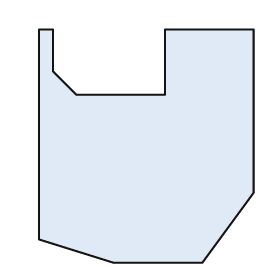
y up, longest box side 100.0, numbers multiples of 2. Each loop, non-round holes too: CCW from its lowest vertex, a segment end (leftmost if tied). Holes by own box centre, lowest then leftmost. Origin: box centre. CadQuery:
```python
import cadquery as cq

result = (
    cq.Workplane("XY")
    .moveTo(-14.0, -50.0)
    .lineTo(24.0, -50.0)
    .lineTo(46.0, -20.0)
    .lineTo(46.0, 50.0)
    .lineTo(8.0, 50.0)
    .lineTo(8.0, 22.0)
    .lineTo(-30.0, 22.0)
    .lineTo(-40.0, 32.0)
    .lineTo(-40.0, 50.0)
    .lineTo(-46.0, 50.0)
    .lineTo(-46.0, -40.0)
    .close()
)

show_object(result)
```